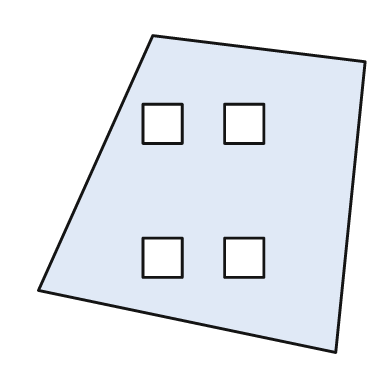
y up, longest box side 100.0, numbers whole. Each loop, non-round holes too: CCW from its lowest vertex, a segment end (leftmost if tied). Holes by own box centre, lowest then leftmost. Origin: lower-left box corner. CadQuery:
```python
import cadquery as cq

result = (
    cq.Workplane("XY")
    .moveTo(91.0, 0.0)
    .lineTo(100.0, 89.0)
    .lineTo(35.0, 97.0)
    .lineTo(0.0, 19.0)
    .close()
    .moveTo(32.0, 23.0)
    .lineTo(44.0, 23.0)
    .lineTo(44.0, 35.0)
    .lineTo(32.0, 35.0)
    .close()
    .moveTo(57.0, 23.0)
    .lineTo(69.0, 23.0)
    .lineTo(69.0, 35.0)
    .lineTo(57.0, 35.0)
    .close()
    .moveTo(32.0, 64.0)
    .lineTo(44.0, 64.0)
    .lineTo(44.0, 76.0)
    .lineTo(32.0, 76.0)
    .close()
    .moveTo(57.0, 64.0)
    .lineTo(69.0, 64.0)
    .lineTo(69.0, 76.0)
    .lineTo(57.0, 76.0)
    .close()
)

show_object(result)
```